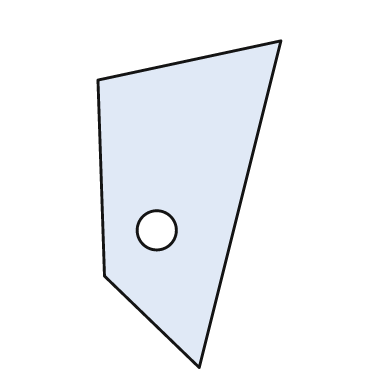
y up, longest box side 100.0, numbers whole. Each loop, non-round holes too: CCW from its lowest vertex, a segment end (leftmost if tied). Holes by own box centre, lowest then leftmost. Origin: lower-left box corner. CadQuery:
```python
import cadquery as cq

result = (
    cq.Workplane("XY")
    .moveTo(31.0, 0.0)
    .lineTo(56.0, 100.0)
    .lineTo(0.0, 88.0)
    .lineTo(2.0, 28.0)
    .close()
    .moveTo(18.0, 42.0)
    .circle(6.0)
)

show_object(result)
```